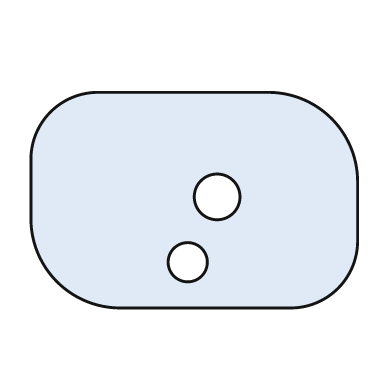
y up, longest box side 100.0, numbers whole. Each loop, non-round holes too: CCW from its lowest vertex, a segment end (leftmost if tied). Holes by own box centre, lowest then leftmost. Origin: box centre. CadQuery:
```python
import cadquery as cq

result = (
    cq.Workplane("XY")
    .moveTo(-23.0, -33.0)
    .lineTo(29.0, -33.0)
    .threePointArc((44.0, -27.0), (50.0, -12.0))
    .lineTo(50.0, 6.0)
    .threePointArc((42.0, 25.0), (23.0, 33.0))
    .lineTo(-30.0, 33.0)
    .threePointArc((-44.0, 27.0), (-50.0, 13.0))
    .lineTo(-50.0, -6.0)
    .threePointArc((-42.0, -25.0), (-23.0, -33.0))
    .close()
    .moveTo(-2.0, -19.0)
    .circle(6.0)
    .moveTo(7.0, 1.0)
    .circle(7.0)
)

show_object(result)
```